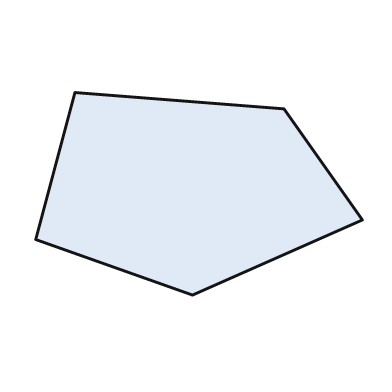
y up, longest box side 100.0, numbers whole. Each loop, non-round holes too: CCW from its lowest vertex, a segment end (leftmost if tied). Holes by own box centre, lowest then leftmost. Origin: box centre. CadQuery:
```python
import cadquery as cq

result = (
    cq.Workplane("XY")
    .moveTo(-2.0, -31.0)
    .lineTo(50.0, -8.0)
    .lineTo(26.0, 26.0)
    .lineTo(-38.0, 31.0)
    .lineTo(-50.0, -14.0)
    .close()
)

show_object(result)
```